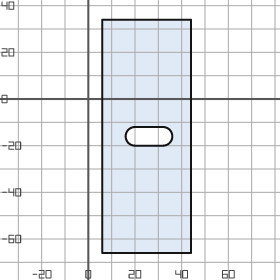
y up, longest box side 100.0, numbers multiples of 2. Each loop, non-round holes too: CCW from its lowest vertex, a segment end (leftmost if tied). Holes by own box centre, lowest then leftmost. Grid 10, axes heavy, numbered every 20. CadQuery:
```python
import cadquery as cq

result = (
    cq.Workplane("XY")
    .moveTo(6.0, -66.0)
    .lineTo(44.0, -66.0)
    .lineTo(44.0, 34.0)
    .lineTo(6.0, 34.0)
    .close()
    .moveTo(20.0, -20.0)
    .lineTo(32.0, -20.0)
    .threePointArc((36.0, -16.0), (32.0, -12.0))
    .lineTo(20.0, -12.0)
    .threePointArc((16.0, -16.0), (20.0, -20.0))
    .close()
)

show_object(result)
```